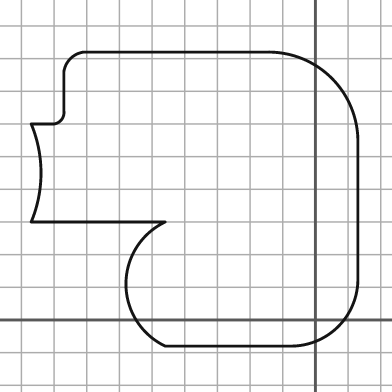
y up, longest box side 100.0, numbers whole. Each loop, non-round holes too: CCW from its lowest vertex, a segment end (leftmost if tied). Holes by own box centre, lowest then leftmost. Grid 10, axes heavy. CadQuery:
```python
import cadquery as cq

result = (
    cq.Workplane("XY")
    .moveTo(-46.0, -8.0)
    .lineTo(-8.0, -8.0)
    .threePointArc((7.0, -2.0), (13.0, 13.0))
    .lineTo(13.0, 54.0)
    .threePointArc((5.0, 74.0), (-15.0, 82.0))
    .lineTo(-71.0, 82.0)
    .threePointArc((-75.0, 80.0), (-77.0, 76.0))
    .lineTo(-77.0, 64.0)
    .threePointArc((-78.0, 61.0), (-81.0, 60.0))
    .lineTo(-87.0, 60.0)
    .threePointArc((-84.0, 45.0), (-87.0, 30.0))
    .lineTo(-46.0, 30.0)
    .threePointArc((-58.0, 11.0), (-46.0, -8.0))
    .close()
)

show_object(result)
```